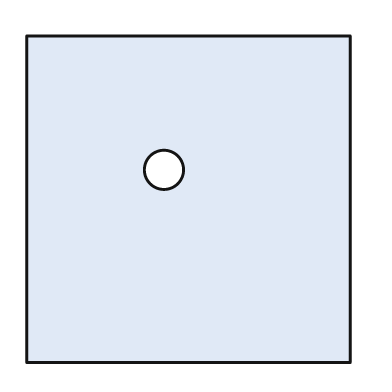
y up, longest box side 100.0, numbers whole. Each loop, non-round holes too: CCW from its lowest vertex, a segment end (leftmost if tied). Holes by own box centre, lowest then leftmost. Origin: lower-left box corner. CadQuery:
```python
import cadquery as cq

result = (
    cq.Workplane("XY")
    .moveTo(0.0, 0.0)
    .lineTo(99.0, 0.0)
    .lineTo(99.0, 100.0)
    .lineTo(0.0, 100.0)
    .close()
    .moveTo(42.0, 59.0)
    .circle(6.0)
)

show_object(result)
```